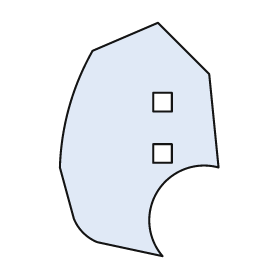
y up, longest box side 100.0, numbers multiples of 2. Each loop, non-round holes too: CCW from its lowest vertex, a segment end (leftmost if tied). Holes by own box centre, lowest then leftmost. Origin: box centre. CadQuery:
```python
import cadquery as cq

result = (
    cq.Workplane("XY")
    .moveTo(10.0, -50.0)
    .threePointArc((8.0, -22.0), (34.0, -12.0))
    .lineTo(30.0, 28.0)
    .lineTo(8.0, 50.0)
    .lineTo(-20.0, 38.0)
    .threePointArc((-30.0, 14.0), (-34.0, -12.0))
    .lineTo(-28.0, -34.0)
    .threePointArc((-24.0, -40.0), (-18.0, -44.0))
    .close()
    .moveTo(6.0, -10.0)
    .lineTo(14.0, -10.0)
    .lineTo(14.0, -2.0)
    .lineTo(6.0, -2.0)
    .close()
    .moveTo(6.0, 12.0)
    .lineTo(14.0, 12.0)
    .lineTo(14.0, 20.0)
    .lineTo(6.0, 20.0)
    .close()
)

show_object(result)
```